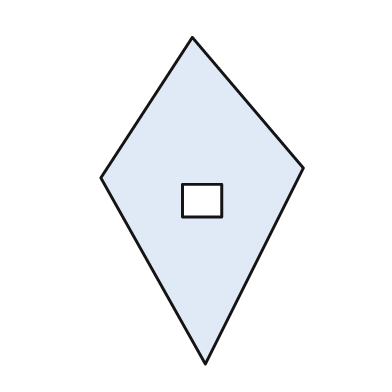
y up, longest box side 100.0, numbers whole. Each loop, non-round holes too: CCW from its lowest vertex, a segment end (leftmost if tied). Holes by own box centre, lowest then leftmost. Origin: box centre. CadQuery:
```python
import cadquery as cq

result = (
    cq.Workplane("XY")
    .moveTo(1.0, -50.0)
    .lineTo(31.0, 10.0)
    .lineTo(-3.0, 50.0)
    .lineTo(-31.0, 7.0)
    .close()
    .moveTo(-6.0, -5.0)
    .lineTo(6.0, -5.0)
    .lineTo(6.0, 5.0)
    .lineTo(-6.0, 5.0)
    .close()
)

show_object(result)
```